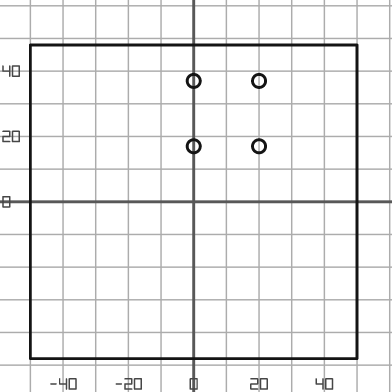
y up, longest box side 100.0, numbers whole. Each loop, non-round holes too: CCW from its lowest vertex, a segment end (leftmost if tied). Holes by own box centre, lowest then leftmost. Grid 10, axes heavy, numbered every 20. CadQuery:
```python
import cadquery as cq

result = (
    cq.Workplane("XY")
    .moveTo(-50.0, -48.0)
    .lineTo(50.0, -48.0)
    .lineTo(50.0, 48.0)
    .lineTo(-50.0, 48.0)
    .close()
    .moveTo(0.0, 17.0)
    .circle(2.0)
    .moveTo(20.0, 17.0)
    .circle(2.0)
    .moveTo(0.0, 37.0)
    .circle(2.0)
    .moveTo(20.0, 37.0)
    .circle(2.0)
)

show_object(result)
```